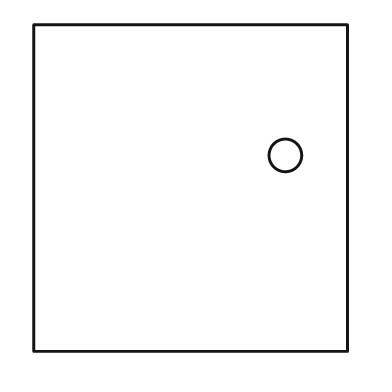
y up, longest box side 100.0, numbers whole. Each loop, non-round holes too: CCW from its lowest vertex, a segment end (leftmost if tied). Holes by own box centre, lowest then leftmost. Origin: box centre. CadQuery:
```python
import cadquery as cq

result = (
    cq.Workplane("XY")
    .moveTo(-48.0, -50.0)
    .lineTo(48.0, -50.0)
    .lineTo(48.0, 50.0)
    .lineTo(-48.0, 50.0)
    .close()
    .moveTo(29.0, 10.0)
    .circle(5.0)
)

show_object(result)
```